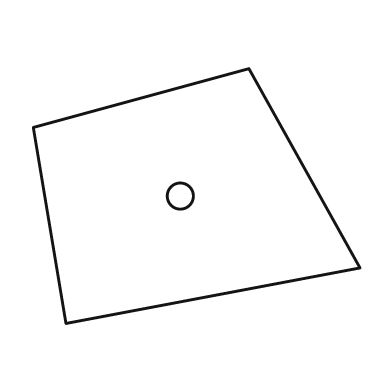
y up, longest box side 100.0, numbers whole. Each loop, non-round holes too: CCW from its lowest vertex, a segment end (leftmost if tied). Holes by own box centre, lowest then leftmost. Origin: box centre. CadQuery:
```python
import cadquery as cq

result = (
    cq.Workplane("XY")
    .moveTo(-40.0, -39.0)
    .lineTo(50.0, -22.0)
    .lineTo(16.0, 39.0)
    .lineTo(-50.0, 21.0)
    .close()
    .moveTo(-5.0, 0.0)
    .circle(4.0)
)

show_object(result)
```